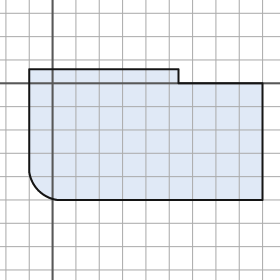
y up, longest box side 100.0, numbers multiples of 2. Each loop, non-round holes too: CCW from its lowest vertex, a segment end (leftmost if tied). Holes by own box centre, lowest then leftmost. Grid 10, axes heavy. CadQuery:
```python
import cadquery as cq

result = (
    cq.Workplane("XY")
    .moveTo(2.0, -50.0)
    .lineTo(90.0, -50.0)
    .lineTo(90.0, 0.0)
    .lineTo(54.0, 0.0)
    .lineTo(54.0, 6.0)
    .lineTo(-10.0, 6.0)
    .lineTo(-10.0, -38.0)
    .threePointArc((-6.0, -46.0), (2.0, -50.0))
    .close()
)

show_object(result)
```